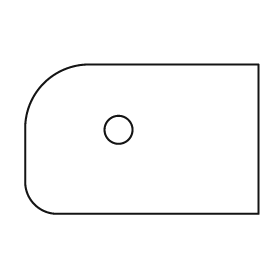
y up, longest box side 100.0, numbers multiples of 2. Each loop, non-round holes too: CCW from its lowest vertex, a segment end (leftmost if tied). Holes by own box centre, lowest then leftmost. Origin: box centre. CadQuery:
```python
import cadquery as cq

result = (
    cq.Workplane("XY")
    .moveTo(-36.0, -32.0)
    .lineTo(50.0, -32.0)
    .lineTo(50.0, 32.0)
    .lineTo(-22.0, 32.0)
    .threePointArc((-42.0, 24.0), (-50.0, 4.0))
    .lineTo(-50.0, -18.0)
    .threePointArc((-46.0, -28.0), (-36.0, -32.0))
    .close()
    .moveTo(-10.0, 4.0)
    .circle(6.0)
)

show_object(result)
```